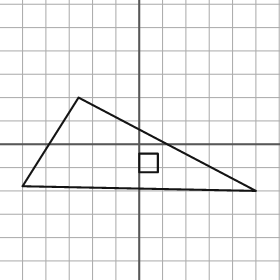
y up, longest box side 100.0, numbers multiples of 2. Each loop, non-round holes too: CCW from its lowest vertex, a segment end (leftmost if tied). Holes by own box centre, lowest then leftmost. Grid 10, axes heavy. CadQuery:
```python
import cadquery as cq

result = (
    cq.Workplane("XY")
    .moveTo(50.0, -20.0)
    .lineTo(-26.0, 20.0)
    .lineTo(-50.0, -18.0)
    .close()
    .moveTo(0.0, -12.0)
    .lineTo(8.0, -12.0)
    .lineTo(8.0, -4.0)
    .lineTo(0.0, -4.0)
    .close()
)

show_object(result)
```